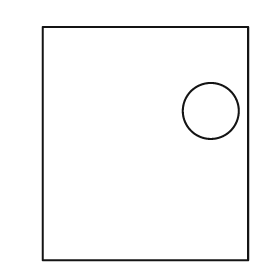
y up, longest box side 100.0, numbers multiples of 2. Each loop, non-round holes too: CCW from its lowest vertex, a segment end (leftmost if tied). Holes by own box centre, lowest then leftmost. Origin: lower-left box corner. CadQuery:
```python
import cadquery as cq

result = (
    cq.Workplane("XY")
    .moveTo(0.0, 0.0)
    .lineTo(88.0, 0.0)
    .lineTo(88.0, 100.0)
    .lineTo(0.0, 100.0)
    .close()
    .moveTo(72.0, 64.0)
    .circle(12.0)
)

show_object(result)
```